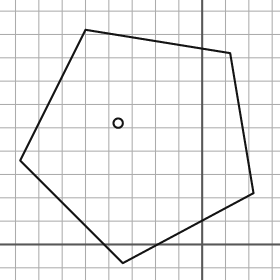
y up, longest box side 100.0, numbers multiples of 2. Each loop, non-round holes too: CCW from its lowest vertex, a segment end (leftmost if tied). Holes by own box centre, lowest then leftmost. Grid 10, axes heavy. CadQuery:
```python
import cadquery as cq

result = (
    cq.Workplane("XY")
    .moveTo(-34.0, -8.0)
    .lineTo(22.0, 22.0)
    .lineTo(12.0, 82.0)
    .lineTo(-50.0, 92.0)
    .lineTo(-78.0, 36.0)
    .close()
    .moveTo(-36.0, 52.0)
    .circle(2.0)
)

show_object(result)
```